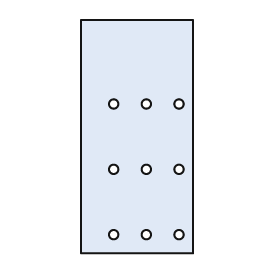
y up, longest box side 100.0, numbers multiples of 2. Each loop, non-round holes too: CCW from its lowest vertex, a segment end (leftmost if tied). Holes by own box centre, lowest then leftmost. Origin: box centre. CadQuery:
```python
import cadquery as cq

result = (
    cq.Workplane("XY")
    .moveTo(-24.0, -50.0)
    .lineTo(24.0, -50.0)
    .lineTo(24.0, 50.0)
    .lineTo(-24.0, 50.0)
    .close()
    .moveTo(-10.0, -42.0)
    .circle(2.0)
    .moveTo(4.0, -42.0)
    .circle(2.0)
    .moveTo(18.0, -42.0)
    .circle(2.0)
    .moveTo(-10.0, -14.0)
    .circle(2.0)
    .moveTo(4.0, -14.0)
    .circle(2.0)
    .moveTo(18.0, -14.0)
    .circle(2.0)
    .moveTo(-10.0, 14.0)
    .circle(2.0)
    .moveTo(4.0, 14.0)
    .circle(2.0)
    .moveTo(18.0, 14.0)
    .circle(2.0)
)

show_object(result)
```